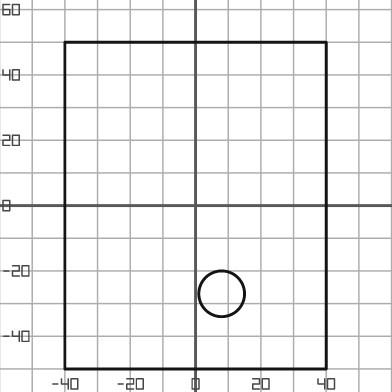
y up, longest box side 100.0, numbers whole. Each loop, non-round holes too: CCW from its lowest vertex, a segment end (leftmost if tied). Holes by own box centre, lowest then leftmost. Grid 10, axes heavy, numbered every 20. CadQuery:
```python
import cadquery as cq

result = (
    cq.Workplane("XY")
    .moveTo(-40.0, -50.0)
    .lineTo(40.0, -50.0)
    .lineTo(40.0, 50.0)
    .lineTo(-40.0, 50.0)
    .close()
    .moveTo(8.0, -27.0)
    .circle(7.0)
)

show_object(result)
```